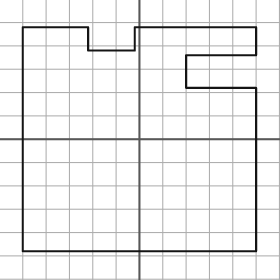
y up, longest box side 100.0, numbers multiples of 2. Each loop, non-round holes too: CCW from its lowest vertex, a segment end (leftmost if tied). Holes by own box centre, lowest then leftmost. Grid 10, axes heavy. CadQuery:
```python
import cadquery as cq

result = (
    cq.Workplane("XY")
    .moveTo(-50.0, -48.0)
    .lineTo(50.0, -48.0)
    .lineTo(50.0, 22.0)
    .lineTo(20.0, 22.0)
    .lineTo(20.0, 36.0)
    .lineTo(50.0, 36.0)
    .lineTo(50.0, 48.0)
    .lineTo(-2.0, 48.0)
    .lineTo(-2.0, 38.0)
    .lineTo(-22.0, 38.0)
    .lineTo(-22.0, 48.0)
    .lineTo(-50.0, 48.0)
    .close()
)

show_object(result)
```